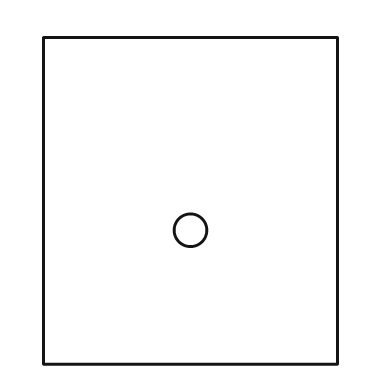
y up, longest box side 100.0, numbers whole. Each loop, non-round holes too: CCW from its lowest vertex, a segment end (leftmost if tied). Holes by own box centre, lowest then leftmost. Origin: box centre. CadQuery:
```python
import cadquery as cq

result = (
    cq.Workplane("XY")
    .moveTo(-45.0, -50.0)
    .lineTo(45.0, -50.0)
    .lineTo(45.0, 50.0)
    .lineTo(-45.0, 50.0)
    .close()
    .moveTo(0.0, -9.0)
    .circle(5.0)
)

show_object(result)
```